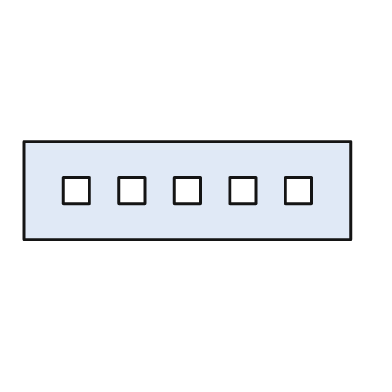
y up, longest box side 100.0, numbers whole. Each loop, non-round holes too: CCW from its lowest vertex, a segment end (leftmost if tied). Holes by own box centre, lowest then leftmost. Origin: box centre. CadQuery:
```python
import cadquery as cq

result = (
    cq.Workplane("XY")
    .moveTo(-50.0, -15.0)
    .lineTo(50.0, -15.0)
    .lineTo(50.0, 15.0)
    .lineTo(-50.0, 15.0)
    .close()
    .moveTo(-38.0, -4.0)
    .lineTo(-30.0, -4.0)
    .lineTo(-30.0, 4.0)
    .lineTo(-38.0, 4.0)
    .close()
    .moveTo(-21.0, -4.0)
    .lineTo(-13.0, -4.0)
    .lineTo(-13.0, 4.0)
    .lineTo(-21.0, 4.0)
    .close()
    .moveTo(-4.0, -4.0)
    .lineTo(4.0, -4.0)
    .lineTo(4.0, 4.0)
    .lineTo(-4.0, 4.0)
    .close()
    .moveTo(13.0, -4.0)
    .lineTo(21.0, -4.0)
    .lineTo(21.0, 4.0)
    .lineTo(13.0, 4.0)
    .close()
    .moveTo(30.0, -4.0)
    .lineTo(38.0, -4.0)
    .lineTo(38.0, 4.0)
    .lineTo(30.0, 4.0)
    .close()
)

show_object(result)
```